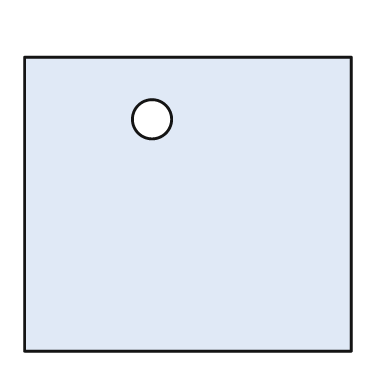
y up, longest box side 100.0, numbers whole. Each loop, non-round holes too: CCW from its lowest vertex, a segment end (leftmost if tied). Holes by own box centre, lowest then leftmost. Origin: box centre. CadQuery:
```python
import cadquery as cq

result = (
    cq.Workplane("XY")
    .moveTo(-50.0, -45.0)
    .lineTo(50.0, -45.0)
    .lineTo(50.0, 45.0)
    .lineTo(-50.0, 45.0)
    .close()
    .moveTo(-11.0, 26.0)
    .circle(6.0)
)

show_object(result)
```